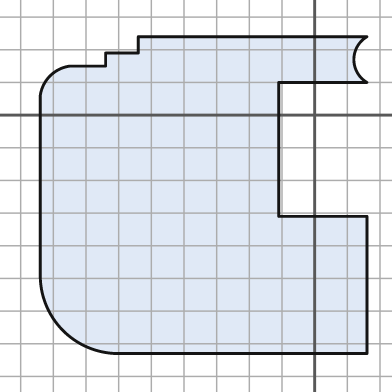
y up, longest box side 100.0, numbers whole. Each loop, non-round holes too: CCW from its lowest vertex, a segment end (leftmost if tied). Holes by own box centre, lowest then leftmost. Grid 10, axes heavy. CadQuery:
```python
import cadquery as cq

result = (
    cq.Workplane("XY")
    .moveTo(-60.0, -73.0)
    .lineTo(16.0, -73.0)
    .lineTo(16.0, -31.0)
    .lineTo(-11.0, -31.0)
    .lineTo(-11.0, 10.0)
    .lineTo(16.0, 10.0)
    .threePointArc((12.0, 17.0), (16.0, 24.0))
    .lineTo(-54.0, 24.0)
    .lineTo(-54.0, 19.0)
    .lineTo(-64.0, 19.0)
    .lineTo(-64.0, 15.0)
    .lineTo(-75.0, 15.0)
    .threePointArc((-81.0, 12.0), (-84.0, 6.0))
    .lineTo(-84.0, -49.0)
    .threePointArc((-77.0, -66.0), (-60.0, -73.0))
    .close()
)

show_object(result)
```